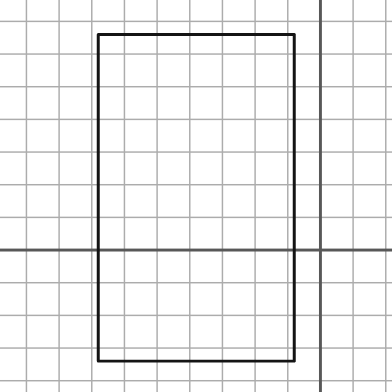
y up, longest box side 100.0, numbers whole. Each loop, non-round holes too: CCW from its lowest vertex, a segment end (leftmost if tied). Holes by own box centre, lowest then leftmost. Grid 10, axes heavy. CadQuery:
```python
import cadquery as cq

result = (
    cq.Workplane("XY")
    .moveTo(-68.0, -34.0)
    .lineTo(-8.0, -34.0)
    .lineTo(-8.0, 66.0)
    .lineTo(-68.0, 66.0)
    .close()
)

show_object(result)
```